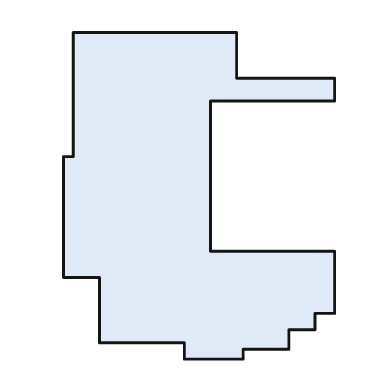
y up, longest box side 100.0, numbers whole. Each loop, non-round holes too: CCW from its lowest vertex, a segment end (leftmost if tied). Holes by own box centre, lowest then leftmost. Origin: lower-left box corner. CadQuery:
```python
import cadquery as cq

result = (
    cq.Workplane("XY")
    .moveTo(37.0, 0.0)
    .lineTo(55.0, 0.0)
    .lineTo(55.0, 3.0)
    .lineTo(69.0, 3.0)
    .lineTo(69.0, 9.0)
    .lineTo(77.0, 9.0)
    .lineTo(77.0, 14.0)
    .lineTo(83.0, 14.0)
    .lineTo(83.0, 33.0)
    .lineTo(45.0, 33.0)
    .lineTo(45.0, 79.0)
    .lineTo(83.0, 79.0)
    .lineTo(83.0, 86.0)
    .lineTo(53.0, 86.0)
    .lineTo(53.0, 100.0)
    .lineTo(3.0, 100.0)
    .lineTo(3.0, 62.0)
    .lineTo(0.0, 62.0)
    .lineTo(0.0, 25.0)
    .lineTo(11.0, 25.0)
    .lineTo(11.0, 5.0)
    .lineTo(37.0, 5.0)
    .close()
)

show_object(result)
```